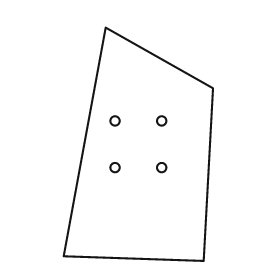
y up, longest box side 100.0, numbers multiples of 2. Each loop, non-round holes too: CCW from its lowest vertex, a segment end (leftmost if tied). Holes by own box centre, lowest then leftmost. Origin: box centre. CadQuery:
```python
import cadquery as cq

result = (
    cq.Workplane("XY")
    .moveTo(28.0, -50.0)
    .lineTo(32.0, 24.0)
    .lineTo(-14.0, 50.0)
    .lineTo(-32.0, -48.0)
    .close()
    .moveTo(-10.0, -10.0)
    .circle(2.0)
    .moveTo(10.0, -10.0)
    .circle(2.0)
    .moveTo(-10.0, 10.0)
    .circle(2.0)
    .moveTo(10.0, 10.0)
    .circle(2.0)
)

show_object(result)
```